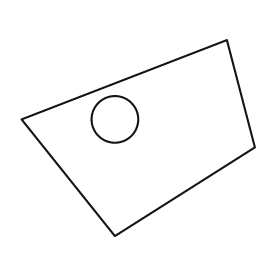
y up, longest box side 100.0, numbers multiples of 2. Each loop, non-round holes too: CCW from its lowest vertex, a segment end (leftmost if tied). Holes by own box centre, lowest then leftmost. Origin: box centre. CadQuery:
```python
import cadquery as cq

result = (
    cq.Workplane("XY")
    .moveTo(-10.0, -42.0)
    .lineTo(50.0, -4.0)
    .lineTo(38.0, 42.0)
    .lineTo(-50.0, 8.0)
    .close()
    .moveTo(-10.0, 8.0)
    .circle(10.0)
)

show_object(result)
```